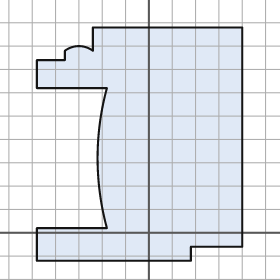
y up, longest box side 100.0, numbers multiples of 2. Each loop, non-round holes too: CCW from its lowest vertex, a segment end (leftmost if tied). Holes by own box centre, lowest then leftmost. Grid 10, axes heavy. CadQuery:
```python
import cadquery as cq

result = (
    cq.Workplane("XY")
    .moveTo(-48.0, -12.0)
    .lineTo(18.0, -12.0)
    .lineTo(18.0, -6.0)
    .lineTo(40.0, -6.0)
    .lineTo(40.0, 88.0)
    .lineTo(-24.0, 88.0)
    .lineTo(-24.0, 78.0)
    .threePointArc((-30.0, 80.0), (-36.0, 78.0))
    .lineTo(-36.0, 74.0)
    .lineTo(-48.0, 74.0)
    .lineTo(-48.0, 62.0)
    .lineTo(-18.0, 62.0)
    .threePointArc((-22.0, 32.0), (-18.0, 2.0))
    .lineTo(-48.0, 2.0)
    .close()
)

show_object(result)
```